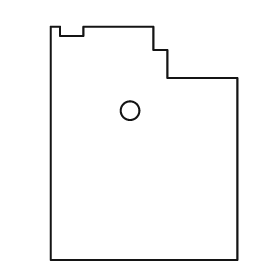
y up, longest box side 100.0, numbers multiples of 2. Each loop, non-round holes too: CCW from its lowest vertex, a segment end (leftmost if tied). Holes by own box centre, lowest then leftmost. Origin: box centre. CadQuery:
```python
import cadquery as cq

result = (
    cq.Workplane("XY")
    .moveTo(-40.0, -50.0)
    .lineTo(40.0, -50.0)
    .lineTo(40.0, 28.0)
    .lineTo(10.0, 28.0)
    .lineTo(10.0, 40.0)
    .lineTo(4.0, 40.0)
    .lineTo(4.0, 50.0)
    .lineTo(-26.0, 50.0)
    .lineTo(-26.0, 46.0)
    .lineTo(-36.0, 46.0)
    .lineTo(-36.0, 50.0)
    .lineTo(-40.0, 50.0)
    .close()
    .moveTo(-6.0, 14.0)
    .circle(4.0)
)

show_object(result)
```